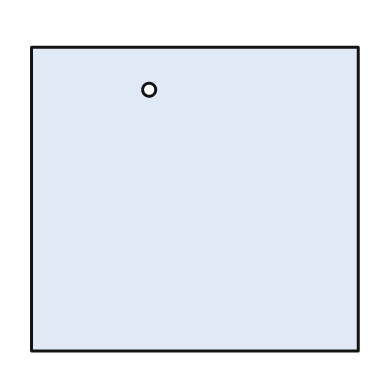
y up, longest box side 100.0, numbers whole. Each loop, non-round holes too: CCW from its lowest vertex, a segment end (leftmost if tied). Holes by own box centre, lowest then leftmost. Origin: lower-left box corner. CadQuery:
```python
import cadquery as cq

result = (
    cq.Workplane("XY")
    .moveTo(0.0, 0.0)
    .lineTo(100.0, 0.0)
    .lineTo(100.0, 93.0)
    .lineTo(0.0, 93.0)
    .close()
    .moveTo(36.0, 80.0)
    .circle(2.0)
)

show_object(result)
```